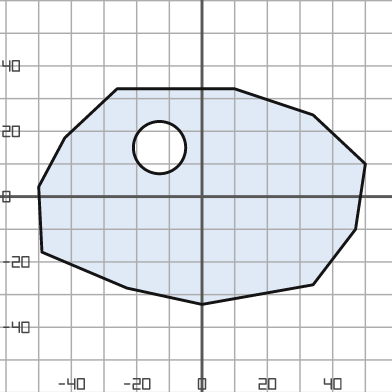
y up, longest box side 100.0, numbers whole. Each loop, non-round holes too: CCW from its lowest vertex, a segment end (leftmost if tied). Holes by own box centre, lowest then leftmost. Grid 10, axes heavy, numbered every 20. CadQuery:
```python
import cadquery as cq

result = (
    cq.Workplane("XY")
    .moveTo(0.0, -33.0)
    .lineTo(34.0, -27.0)
    .lineTo(47.0, -10.0)
    .lineTo(50.0, 10.0)
    .lineTo(34.0, 25.0)
    .lineTo(10.0, 33.0)
    .lineTo(-26.0, 33.0)
    .lineTo(-42.0, 18.0)
    .lineTo(-50.0, 3.0)
    .lineTo(-49.0, -17.0)
    .lineTo(-23.0, -28.0)
    .close()
    .moveTo(-13.0, 15.0)
    .circle(8.0)
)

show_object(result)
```